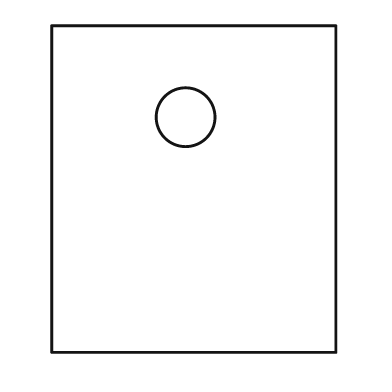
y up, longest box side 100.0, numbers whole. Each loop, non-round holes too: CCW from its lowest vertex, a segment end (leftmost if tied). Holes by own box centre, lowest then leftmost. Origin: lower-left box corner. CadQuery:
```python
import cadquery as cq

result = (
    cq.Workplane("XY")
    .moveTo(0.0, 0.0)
    .lineTo(87.0, 0.0)
    .lineTo(87.0, 100.0)
    .lineTo(0.0, 100.0)
    .close()
    .moveTo(41.0, 72.0)
    .circle(9.0)
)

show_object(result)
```